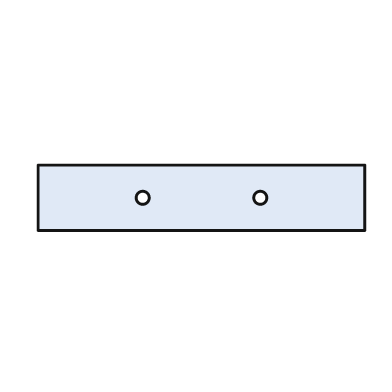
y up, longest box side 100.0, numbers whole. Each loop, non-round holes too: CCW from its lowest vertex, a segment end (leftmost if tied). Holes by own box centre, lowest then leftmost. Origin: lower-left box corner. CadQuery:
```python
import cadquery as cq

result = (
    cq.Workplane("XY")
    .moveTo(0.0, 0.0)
    .lineTo(100.0, 0.0)
    .lineTo(100.0, 20.0)
    .lineTo(0.0, 20.0)
    .close()
    .moveTo(32.0, 10.0)
    .circle(2.0)
    .moveTo(68.0, 10.0)
    .circle(2.0)
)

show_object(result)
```